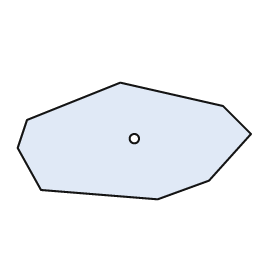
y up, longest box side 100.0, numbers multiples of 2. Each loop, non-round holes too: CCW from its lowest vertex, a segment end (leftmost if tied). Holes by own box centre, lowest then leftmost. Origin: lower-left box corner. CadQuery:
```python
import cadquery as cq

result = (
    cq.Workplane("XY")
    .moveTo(60.0, 0.0)
    .lineTo(82.0, 8.0)
    .lineTo(100.0, 28.0)
    .lineTo(88.0, 40.0)
    .lineTo(44.0, 50.0)
    .lineTo(4.0, 34.0)
    .lineTo(0.0, 22.0)
    .lineTo(10.0, 4.0)
    .close()
    .moveTo(50.0, 26.0)
    .circle(2.0)
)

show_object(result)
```